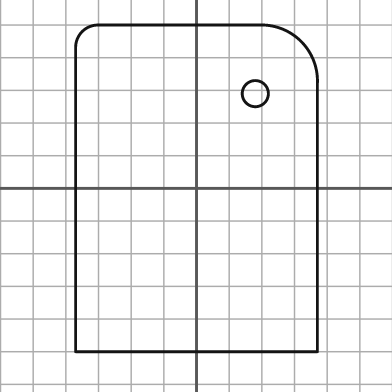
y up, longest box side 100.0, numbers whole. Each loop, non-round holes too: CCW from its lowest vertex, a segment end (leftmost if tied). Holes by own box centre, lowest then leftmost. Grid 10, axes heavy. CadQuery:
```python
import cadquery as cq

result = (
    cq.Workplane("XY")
    .moveTo(-37.0, -50.0)
    .lineTo(37.0, -50.0)
    .lineTo(37.0, 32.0)
    .threePointArc((32.0, 45.0), (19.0, 50.0))
    .lineTo(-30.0, 50.0)
    .threePointArc((-35.0, 48.0), (-37.0, 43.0))
    .close()
    .moveTo(18.0, 29.0)
    .circle(4.0)
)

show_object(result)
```